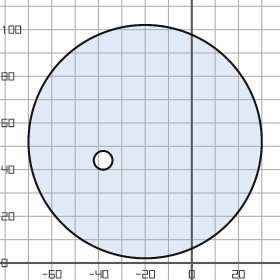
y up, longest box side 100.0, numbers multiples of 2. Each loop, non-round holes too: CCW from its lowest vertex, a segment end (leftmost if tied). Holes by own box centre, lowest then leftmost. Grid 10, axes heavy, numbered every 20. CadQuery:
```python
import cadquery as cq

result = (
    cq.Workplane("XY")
    .moveTo(-20.0, 52.0)
    .circle(50.0)
    .moveTo(-38.0, 44.0)
    .circle(4.0)
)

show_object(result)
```